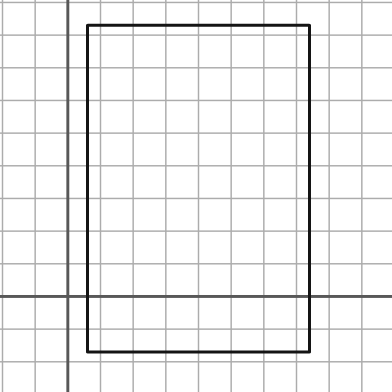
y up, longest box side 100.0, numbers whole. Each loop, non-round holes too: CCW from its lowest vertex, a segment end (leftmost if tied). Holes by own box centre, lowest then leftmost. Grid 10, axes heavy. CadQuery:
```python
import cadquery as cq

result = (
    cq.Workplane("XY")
    .moveTo(6.0, -17.0)
    .lineTo(74.0, -17.0)
    .lineTo(74.0, 83.0)
    .lineTo(6.0, 83.0)
    .close()
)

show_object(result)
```